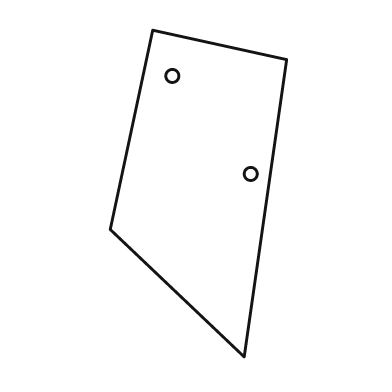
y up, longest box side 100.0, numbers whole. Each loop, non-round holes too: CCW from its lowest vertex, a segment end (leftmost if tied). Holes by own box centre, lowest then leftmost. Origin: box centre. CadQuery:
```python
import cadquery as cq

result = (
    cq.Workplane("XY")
    .moveTo(14.0, -50.0)
    .lineTo(27.0, 41.0)
    .lineTo(-14.0, 50.0)
    .lineTo(-27.0, -11.0)
    .close()
    .moveTo(16.0, 6.0)
    .circle(2.0)
    .moveTo(-8.0, 36.0)
    .circle(2.0)
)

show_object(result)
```